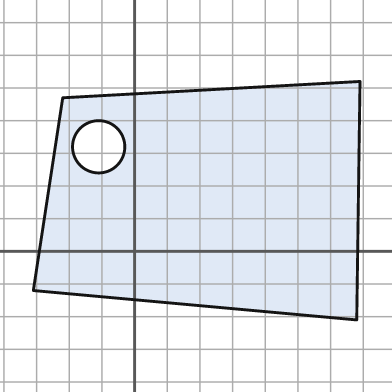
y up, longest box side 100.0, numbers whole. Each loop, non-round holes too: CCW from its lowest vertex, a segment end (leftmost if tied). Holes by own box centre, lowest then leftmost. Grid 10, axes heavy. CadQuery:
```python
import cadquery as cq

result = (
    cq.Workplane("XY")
    .moveTo(68.0, -21.0)
    .lineTo(69.0, 52.0)
    .lineTo(-22.0, 47.0)
    .lineTo(-31.0, -12.0)
    .close()
    .moveTo(-11.0, 32.0)
    .circle(8.0)
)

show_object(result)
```